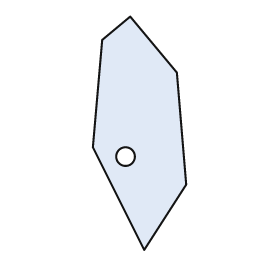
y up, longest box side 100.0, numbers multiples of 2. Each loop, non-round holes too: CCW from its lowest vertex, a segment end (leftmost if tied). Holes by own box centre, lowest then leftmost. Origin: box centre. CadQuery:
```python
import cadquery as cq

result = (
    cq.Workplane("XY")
    .moveTo(2.0, -50.0)
    .lineTo(20.0, -22.0)
    .lineTo(16.0, 26.0)
    .lineTo(-4.0, 50.0)
    .lineTo(-16.0, 40.0)
    .lineTo(-20.0, -6.0)
    .close()
    .moveTo(-6.0, -10.0)
    .circle(4.0)
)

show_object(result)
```